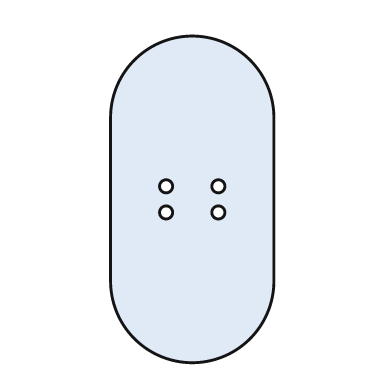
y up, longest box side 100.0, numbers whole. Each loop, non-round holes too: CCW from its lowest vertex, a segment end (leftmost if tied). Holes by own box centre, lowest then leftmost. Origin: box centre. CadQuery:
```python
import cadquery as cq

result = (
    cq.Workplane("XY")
    .moveTo(-25.0, -25.0)
    .threePointArc((0.0, -50.0), (25.0, -25.0))
    .lineTo(25.0, 25.0)
    .threePointArc((0.0, 50.0), (-25.0, 25.0))
    .close()
    .moveTo(-8.0, -4.0)
    .circle(2.0)
    .moveTo(8.0, -4.0)
    .circle(2.0)
    .moveTo(-8.0, 4.0)
    .circle(2.0)
    .moveTo(8.0, 4.0)
    .circle(2.0)
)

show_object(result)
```